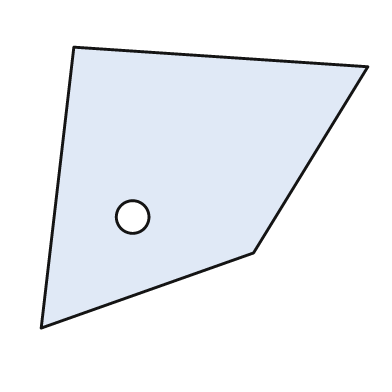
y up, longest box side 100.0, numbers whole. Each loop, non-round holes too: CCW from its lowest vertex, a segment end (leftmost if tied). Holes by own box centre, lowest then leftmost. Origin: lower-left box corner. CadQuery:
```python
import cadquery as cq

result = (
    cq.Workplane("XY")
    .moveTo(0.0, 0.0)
    .lineTo(65.0, 23.0)
    .lineTo(100.0, 80.0)
    .lineTo(10.0, 86.0)
    .close()
    .moveTo(28.0, 34.0)
    .circle(5.0)
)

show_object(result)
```